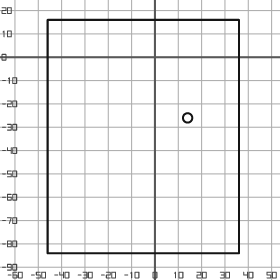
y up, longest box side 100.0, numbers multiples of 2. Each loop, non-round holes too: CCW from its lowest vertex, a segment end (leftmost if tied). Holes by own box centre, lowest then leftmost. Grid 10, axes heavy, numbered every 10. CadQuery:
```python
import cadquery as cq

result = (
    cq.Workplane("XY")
    .moveTo(-46.0, -84.0)
    .lineTo(36.0, -84.0)
    .lineTo(36.0, 16.0)
    .lineTo(-46.0, 16.0)
    .close()
    .moveTo(14.0, -26.0)
    .circle(2.0)
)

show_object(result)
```